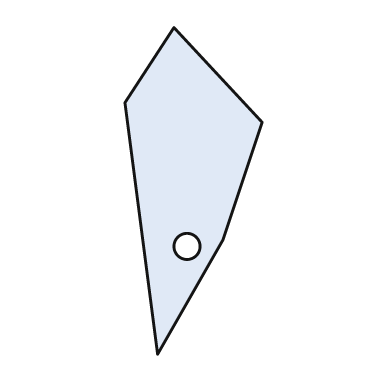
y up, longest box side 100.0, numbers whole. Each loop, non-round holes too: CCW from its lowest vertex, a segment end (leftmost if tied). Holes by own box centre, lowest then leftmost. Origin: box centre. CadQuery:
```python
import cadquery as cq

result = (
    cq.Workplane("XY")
    .moveTo(-11.0, -50.0)
    .lineTo(9.0, -15.0)
    .lineTo(21.0, 21.0)
    .lineTo(-6.0, 50.0)
    .lineTo(-21.0, 27.0)
    .close()
    .moveTo(-2.0, -17.0)
    .circle(4.0)
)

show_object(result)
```